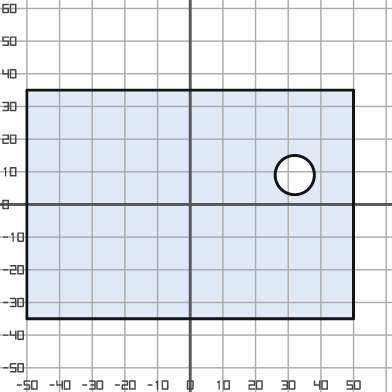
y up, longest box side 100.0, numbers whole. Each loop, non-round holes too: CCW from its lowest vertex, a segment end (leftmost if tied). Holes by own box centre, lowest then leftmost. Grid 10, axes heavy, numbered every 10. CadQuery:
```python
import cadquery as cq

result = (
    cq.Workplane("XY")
    .moveTo(-50.0, -35.0)
    .lineTo(50.0, -35.0)
    .lineTo(50.0, 35.0)
    .lineTo(-50.0, 35.0)
    .close()
    .moveTo(32.0, 9.0)
    .circle(6.0)
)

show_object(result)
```